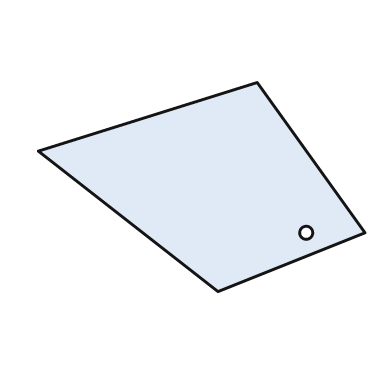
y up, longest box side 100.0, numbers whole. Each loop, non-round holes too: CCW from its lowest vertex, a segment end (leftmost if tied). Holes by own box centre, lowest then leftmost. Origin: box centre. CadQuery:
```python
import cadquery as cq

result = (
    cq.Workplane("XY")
    .moveTo(5.0, -32.0)
    .lineTo(50.0, -14.0)
    .lineTo(17.0, 32.0)
    .lineTo(-50.0, 11.0)
    .close()
    .moveTo(32.0, -14.0)
    .circle(2.0)
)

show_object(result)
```